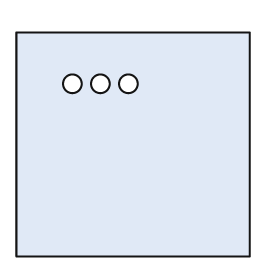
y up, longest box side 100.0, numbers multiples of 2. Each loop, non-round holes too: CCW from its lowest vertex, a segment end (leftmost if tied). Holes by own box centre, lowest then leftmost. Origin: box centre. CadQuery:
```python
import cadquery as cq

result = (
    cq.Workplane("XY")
    .moveTo(-50.0, -48.0)
    .lineTo(50.0, -48.0)
    .lineTo(50.0, 48.0)
    .lineTo(-50.0, 48.0)
    .close()
    .moveTo(-26.0, 26.0)
    .circle(4.0)
    .moveTo(-14.0, 26.0)
    .circle(4.0)
    .moveTo(-2.0, 26.0)
    .circle(4.0)
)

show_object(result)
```